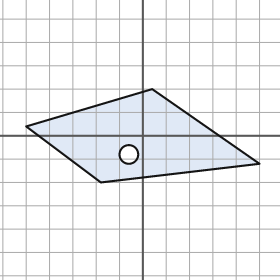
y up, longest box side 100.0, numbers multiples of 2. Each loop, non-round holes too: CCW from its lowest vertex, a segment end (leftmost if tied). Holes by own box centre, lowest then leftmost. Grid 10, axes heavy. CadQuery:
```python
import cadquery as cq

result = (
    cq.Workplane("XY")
    .moveTo(-18.0, -20.0)
    .lineTo(50.0, -12.0)
    .lineTo(4.0, 20.0)
    .lineTo(-50.0, 4.0)
    .close()
    .moveTo(-6.0, -8.0)
    .circle(4.0)
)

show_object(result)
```